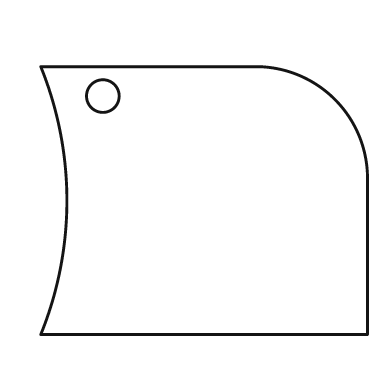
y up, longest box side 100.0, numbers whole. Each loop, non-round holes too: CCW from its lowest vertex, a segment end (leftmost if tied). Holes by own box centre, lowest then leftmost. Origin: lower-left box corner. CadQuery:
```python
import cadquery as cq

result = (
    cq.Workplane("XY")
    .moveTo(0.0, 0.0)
    .lineTo(100.0, 0.0)
    .lineTo(100.0, 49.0)
    .threePointArc((90.0, 72.0), (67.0, 82.0))
    .lineTo(0.0, 82.0)
    .threePointArc((8.0, 41.0), (0.0, 0.0))
    .close()
    .moveTo(19.0, 73.0)
    .circle(5.0)
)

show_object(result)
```